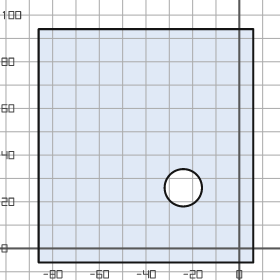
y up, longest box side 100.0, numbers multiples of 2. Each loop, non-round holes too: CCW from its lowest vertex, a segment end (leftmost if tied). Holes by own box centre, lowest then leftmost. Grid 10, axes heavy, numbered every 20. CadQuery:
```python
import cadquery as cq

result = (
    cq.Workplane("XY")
    .moveTo(-86.0, -6.0)
    .lineTo(6.0, -6.0)
    .lineTo(6.0, 94.0)
    .lineTo(-86.0, 94.0)
    .close()
    .moveTo(-24.0, 26.0)
    .circle(8.0)
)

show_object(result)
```